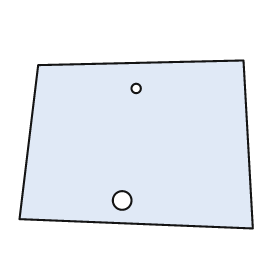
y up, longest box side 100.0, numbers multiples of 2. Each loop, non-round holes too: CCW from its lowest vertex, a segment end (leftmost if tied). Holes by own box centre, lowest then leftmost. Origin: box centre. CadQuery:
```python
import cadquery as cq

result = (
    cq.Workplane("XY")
    .moveTo(50.0, -36.0)
    .lineTo(46.0, 36.0)
    .lineTo(-42.0, 34.0)
    .lineTo(-50.0, -32.0)
    .close()
    .moveTo(-6.0, -24.0)
    .circle(4.0)
    .moveTo(0.0, 24.0)
    .circle(2.0)
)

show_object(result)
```